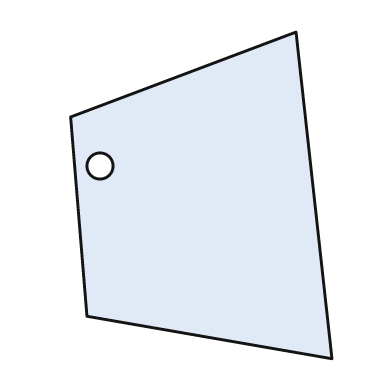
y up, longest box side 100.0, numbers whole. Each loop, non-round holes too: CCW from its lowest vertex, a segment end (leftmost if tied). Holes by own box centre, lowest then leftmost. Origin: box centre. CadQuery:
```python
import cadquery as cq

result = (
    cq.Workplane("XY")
    .moveTo(40.0, -50.0)
    .lineTo(29.0, 50.0)
    .lineTo(-40.0, 24.0)
    .lineTo(-35.0, -37.0)
    .close()
    .moveTo(-31.0, 9.0)
    .circle(4.0)
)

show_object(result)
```